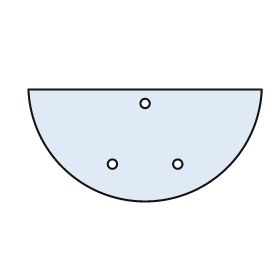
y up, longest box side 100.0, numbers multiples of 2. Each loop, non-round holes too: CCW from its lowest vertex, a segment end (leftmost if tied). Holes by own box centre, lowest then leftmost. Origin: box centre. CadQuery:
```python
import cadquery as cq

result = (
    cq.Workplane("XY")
    .moveTo(-50.0, 24.0)
    .threePointArc((0.0, -24.0), (50.0, 24.0))
    .close()
    .moveTo(-14.0, -8.0)
    .circle(2.0)
    .moveTo(14.0, -8.0)
    .circle(2.0)
    .moveTo(0.0, 18.0)
    .circle(2.0)
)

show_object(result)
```